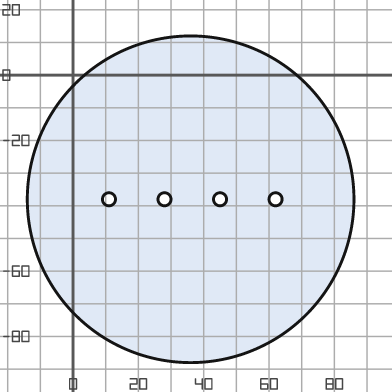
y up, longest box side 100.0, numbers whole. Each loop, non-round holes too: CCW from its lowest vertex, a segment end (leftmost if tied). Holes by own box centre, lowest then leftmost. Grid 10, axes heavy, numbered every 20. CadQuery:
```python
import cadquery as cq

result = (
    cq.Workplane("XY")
    .moveTo(36.0, -38.0)
    .circle(50.0)
    .moveTo(11.0, -38.0)
    .circle(2.0)
    .moveTo(28.0, -38.0)
    .circle(2.0)
    .moveTo(45.0, -38.0)
    .circle(2.0)
    .moveTo(62.0, -38.0)
    .circle(2.0)
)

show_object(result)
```